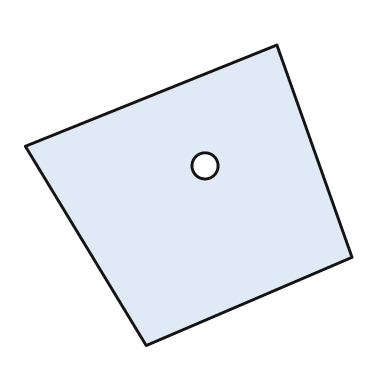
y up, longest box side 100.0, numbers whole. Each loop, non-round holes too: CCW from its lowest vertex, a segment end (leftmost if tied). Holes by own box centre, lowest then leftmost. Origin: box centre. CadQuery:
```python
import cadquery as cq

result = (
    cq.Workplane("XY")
    .moveTo(-13.0, -46.0)
    .lineTo(50.0, -19.0)
    .lineTo(27.0, 46.0)
    .lineTo(-50.0, 15.0)
    .close()
    .moveTo(5.0, 9.0)
    .circle(4.0)
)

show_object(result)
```